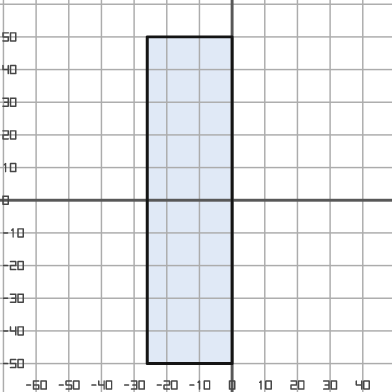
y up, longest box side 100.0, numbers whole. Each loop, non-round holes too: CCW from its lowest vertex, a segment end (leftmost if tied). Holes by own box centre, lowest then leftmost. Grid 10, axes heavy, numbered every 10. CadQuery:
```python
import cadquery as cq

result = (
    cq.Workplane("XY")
    .moveTo(-26.0, -50.0)
    .lineTo(0.0, -50.0)
    .lineTo(0.0, 50.0)
    .lineTo(-26.0, 50.0)
    .close()
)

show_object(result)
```